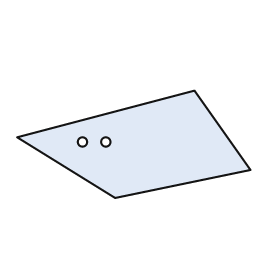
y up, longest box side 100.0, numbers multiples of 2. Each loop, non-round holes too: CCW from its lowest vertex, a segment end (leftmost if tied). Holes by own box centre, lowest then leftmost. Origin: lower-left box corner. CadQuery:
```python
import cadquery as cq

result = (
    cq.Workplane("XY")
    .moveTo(42.0, 0.0)
    .lineTo(100.0, 12.0)
    .lineTo(76.0, 46.0)
    .lineTo(0.0, 26.0)
    .close()
    .moveTo(28.0, 24.0)
    .circle(2.0)
    .moveTo(38.0, 24.0)
    .circle(2.0)
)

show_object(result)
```